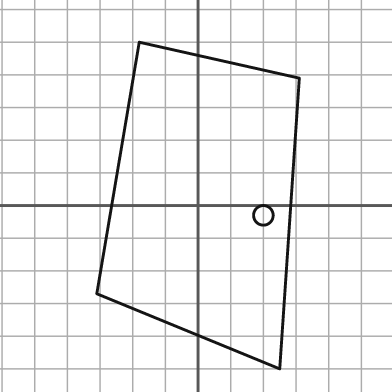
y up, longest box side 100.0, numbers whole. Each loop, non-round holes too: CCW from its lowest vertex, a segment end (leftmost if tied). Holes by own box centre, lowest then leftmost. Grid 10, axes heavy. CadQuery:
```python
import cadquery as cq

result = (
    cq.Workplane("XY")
    .moveTo(25.0, -50.0)
    .lineTo(31.0, 39.0)
    .lineTo(-18.0, 50.0)
    .lineTo(-31.0, -27.0)
    .close()
    .moveTo(20.0, -3.0)
    .circle(3.0)
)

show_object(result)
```